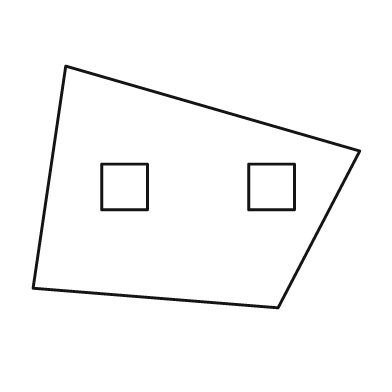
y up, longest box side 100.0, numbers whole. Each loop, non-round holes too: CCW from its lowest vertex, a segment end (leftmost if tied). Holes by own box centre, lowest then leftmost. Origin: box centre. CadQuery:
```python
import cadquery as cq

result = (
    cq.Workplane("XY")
    .moveTo(25.0, -37.0)
    .lineTo(50.0, 11.0)
    .lineTo(-40.0, 37.0)
    .lineTo(-50.0, -31.0)
    .close()
    .moveTo(-29.0, -7.0)
    .lineTo(-15.0, -7.0)
    .lineTo(-15.0, 7.0)
    .lineTo(-29.0, 7.0)
    .close()
    .moveTo(16.0, -7.0)
    .lineTo(30.0, -7.0)
    .lineTo(30.0, 7.0)
    .lineTo(16.0, 7.0)
    .close()
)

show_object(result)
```